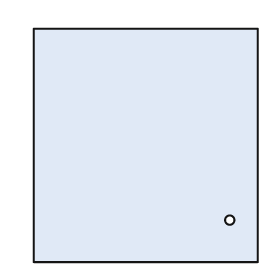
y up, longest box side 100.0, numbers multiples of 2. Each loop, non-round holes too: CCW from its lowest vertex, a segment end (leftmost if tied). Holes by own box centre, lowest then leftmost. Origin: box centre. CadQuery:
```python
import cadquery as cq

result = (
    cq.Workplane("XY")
    .moveTo(-48.0, -50.0)
    .lineTo(48.0, -50.0)
    .lineTo(48.0, 50.0)
    .lineTo(-48.0, 50.0)
    .close()
    .moveTo(36.0, -32.0)
    .circle(2.0)
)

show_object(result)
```